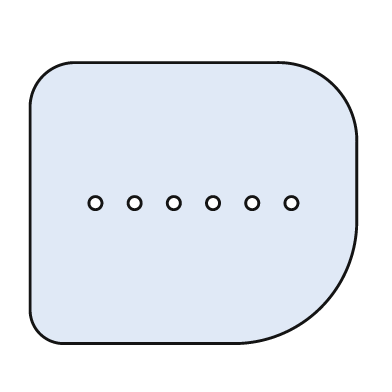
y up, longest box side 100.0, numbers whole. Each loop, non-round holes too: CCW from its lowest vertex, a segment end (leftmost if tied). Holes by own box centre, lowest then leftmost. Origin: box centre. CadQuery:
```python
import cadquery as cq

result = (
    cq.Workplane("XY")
    .moveTo(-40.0, -43.0)
    .lineTo(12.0, -43.0)
    .threePointArc((39.0, -32.0), (50.0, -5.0))
    .lineTo(50.0, 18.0)
    .threePointArc((43.0, 36.0), (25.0, 43.0))
    .lineTo(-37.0, 43.0)
    .threePointArc((-46.0, 39.0), (-50.0, 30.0))
    .lineTo(-50.0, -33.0)
    .threePointArc((-47.0, -40.0), (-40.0, -43.0))
    .close()
    .moveTo(-30.0, 0.0)
    .circle(2.0)
    .moveTo(-18.0, 0.0)
    .circle(2.0)
    .moveTo(-6.0, 0.0)
    .circle(2.0)
    .moveTo(6.0, 0.0)
    .circle(2.0)
    .moveTo(18.0, 0.0)
    .circle(2.0)
    .moveTo(30.0, 0.0)
    .circle(2.0)
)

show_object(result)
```